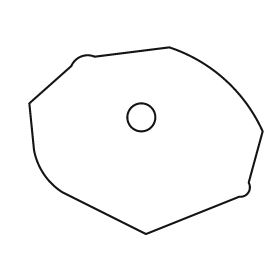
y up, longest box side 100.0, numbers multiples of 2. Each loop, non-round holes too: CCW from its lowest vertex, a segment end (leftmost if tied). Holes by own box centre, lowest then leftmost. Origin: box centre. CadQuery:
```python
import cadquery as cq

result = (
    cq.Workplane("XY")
    .moveTo(0.0, -40.0)
    .lineTo(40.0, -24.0)
    .threePointArc((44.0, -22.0), (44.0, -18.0))
    .lineTo(50.0, 4.0)
    .threePointArc((34.0, 26.0), (10.0, 40.0))
    .lineTo(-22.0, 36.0)
    .threePointArc((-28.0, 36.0), (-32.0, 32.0))
    .lineTo(-50.0, 16.0)
    .lineTo(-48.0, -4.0)
    .threePointArc((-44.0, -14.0), (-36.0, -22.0))
    .close()
    .moveTo(-2.0, 10.0)
    .circle(6.0)
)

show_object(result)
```